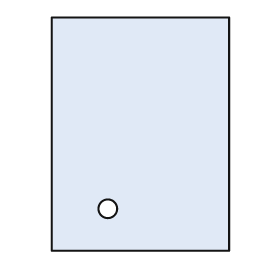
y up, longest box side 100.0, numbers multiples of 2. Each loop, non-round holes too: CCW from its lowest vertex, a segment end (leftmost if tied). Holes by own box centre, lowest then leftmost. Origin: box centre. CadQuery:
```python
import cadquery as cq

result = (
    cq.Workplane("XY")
    .moveTo(-38.0, -50.0)
    .lineTo(38.0, -50.0)
    .lineTo(38.0, 50.0)
    .lineTo(-38.0, 50.0)
    .close()
    .moveTo(-14.0, -32.0)
    .circle(4.0)
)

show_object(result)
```